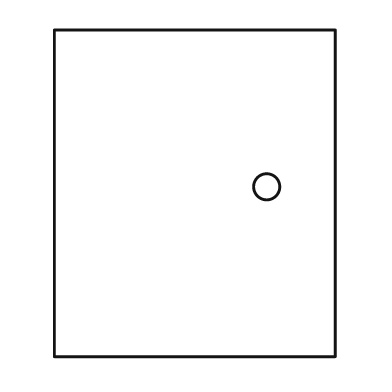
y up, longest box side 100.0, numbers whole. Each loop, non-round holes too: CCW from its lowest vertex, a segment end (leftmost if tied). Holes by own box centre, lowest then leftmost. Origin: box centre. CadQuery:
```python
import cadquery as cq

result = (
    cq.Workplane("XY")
    .moveTo(-43.0, -50.0)
    .lineTo(43.0, -50.0)
    .lineTo(43.0, 50.0)
    .lineTo(-43.0, 50.0)
    .close()
    .moveTo(22.0, 2.0)
    .circle(4.0)
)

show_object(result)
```